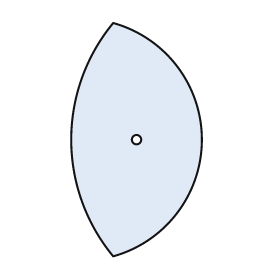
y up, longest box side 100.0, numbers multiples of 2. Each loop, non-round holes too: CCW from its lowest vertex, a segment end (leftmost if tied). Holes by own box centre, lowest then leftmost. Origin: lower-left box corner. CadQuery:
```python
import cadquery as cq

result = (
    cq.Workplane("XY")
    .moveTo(18.0, 0.0)
    .threePointArc((56.0, 50.0), (18.0, 100.0))
    .threePointArc((0.0, 50.0), (18.0, 0.0))
    .close()
    .moveTo(28.0, 50.0)
    .circle(2.0)
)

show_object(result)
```